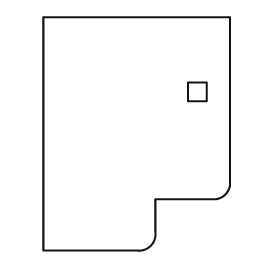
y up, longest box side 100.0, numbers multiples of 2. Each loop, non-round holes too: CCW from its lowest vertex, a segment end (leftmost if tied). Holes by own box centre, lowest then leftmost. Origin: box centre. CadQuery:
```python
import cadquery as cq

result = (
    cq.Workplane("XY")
    .moveTo(-40.0, -50.0)
    .lineTo(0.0, -50.0)
    .threePointArc((6.0, -48.0), (8.0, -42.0))
    .lineTo(8.0, -28.0)
    .lineTo(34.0, -28.0)
    .threePointArc((38.0, -26.0), (40.0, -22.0))
    .lineTo(40.0, 50.0)
    .lineTo(-40.0, 50.0)
    .close()
    .moveTo(22.0, 14.0)
    .lineTo(30.0, 14.0)
    .lineTo(30.0, 22.0)
    .lineTo(22.0, 22.0)
    .close()
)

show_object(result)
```